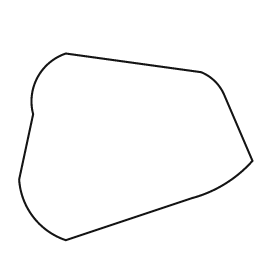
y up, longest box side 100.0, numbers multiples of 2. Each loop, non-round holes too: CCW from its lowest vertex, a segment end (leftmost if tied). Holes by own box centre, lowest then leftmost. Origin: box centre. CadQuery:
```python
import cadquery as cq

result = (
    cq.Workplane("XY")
    .moveTo(-30.0, -40.0)
    .lineTo(24.0, -22.0)
    .threePointArc((38.0, -16.0), (50.0, -6.0))
    .lineTo(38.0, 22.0)
    .threePointArc((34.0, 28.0), (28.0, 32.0))
    .lineTo(-30.0, 40.0)
    .threePointArc((-42.0, 30.0), (-44.0, 14.0))
    .lineTo(-50.0, -14.0)
    .threePointArc((-44.0, -30.0), (-30.0, -40.0))
    .close()
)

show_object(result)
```